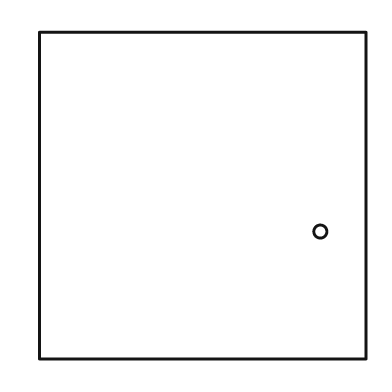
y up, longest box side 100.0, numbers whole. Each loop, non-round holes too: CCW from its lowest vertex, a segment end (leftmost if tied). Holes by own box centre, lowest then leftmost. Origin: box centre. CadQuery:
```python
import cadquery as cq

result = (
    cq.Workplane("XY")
    .moveTo(-50.0, -50.0)
    .lineTo(50.0, -50.0)
    .lineTo(50.0, 50.0)
    .lineTo(-50.0, 50.0)
    .close()
    .moveTo(36.0, -11.0)
    .circle(2.0)
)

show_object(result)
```